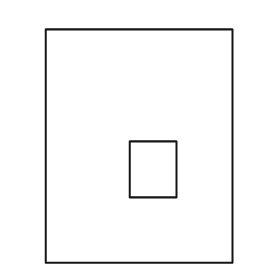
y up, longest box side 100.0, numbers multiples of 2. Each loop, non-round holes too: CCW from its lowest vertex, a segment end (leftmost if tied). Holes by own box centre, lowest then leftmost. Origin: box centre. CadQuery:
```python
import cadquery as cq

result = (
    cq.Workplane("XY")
    .moveTo(-40.0, -50.0)
    .lineTo(40.0, -50.0)
    .lineTo(40.0, 50.0)
    .lineTo(-40.0, 50.0)
    .close()
    .moveTo(-4.0, -22.0)
    .lineTo(16.0, -22.0)
    .lineTo(16.0, 2.0)
    .lineTo(-4.0, 2.0)
    .close()
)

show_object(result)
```